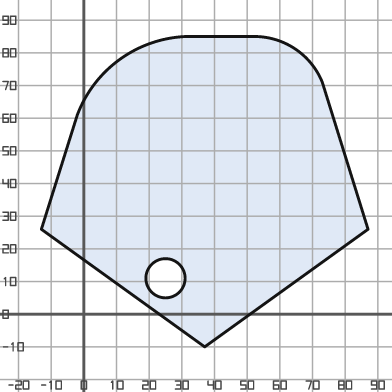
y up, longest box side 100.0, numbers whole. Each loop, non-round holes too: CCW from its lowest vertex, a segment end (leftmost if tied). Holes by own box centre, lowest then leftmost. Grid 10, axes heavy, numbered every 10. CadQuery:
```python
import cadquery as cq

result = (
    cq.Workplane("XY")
    .moveTo(37.0, -10.0)
    .lineTo(87.0, 26.0)
    .lineTo(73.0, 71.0)
    .threePointArc((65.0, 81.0), (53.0, 85.0))
    .lineTo(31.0, 85.0)
    .threePointArc((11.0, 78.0), (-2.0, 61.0))
    .lineTo(-13.0, 26.0)
    .close()
    .moveTo(25.0, 11.0)
    .circle(6.0)
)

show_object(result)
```